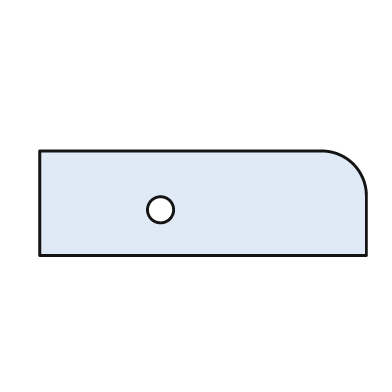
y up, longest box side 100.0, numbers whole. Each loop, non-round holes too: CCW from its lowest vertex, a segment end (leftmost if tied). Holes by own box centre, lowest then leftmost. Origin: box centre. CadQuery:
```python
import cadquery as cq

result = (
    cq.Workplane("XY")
    .moveTo(-50.0, -16.0)
    .lineTo(50.0, -16.0)
    .lineTo(50.0, 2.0)
    .threePointArc((46.0, 12.0), (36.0, 16.0))
    .lineTo(-50.0, 16.0)
    .close()
    .moveTo(-13.0, -2.0)
    .circle(4.0)
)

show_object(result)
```